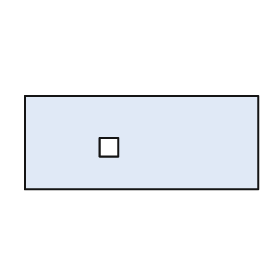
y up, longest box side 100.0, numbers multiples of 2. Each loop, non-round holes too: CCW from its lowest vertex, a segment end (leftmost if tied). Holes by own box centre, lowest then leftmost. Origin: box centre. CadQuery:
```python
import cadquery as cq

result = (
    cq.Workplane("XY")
    .moveTo(-50.0, -20.0)
    .lineTo(50.0, -20.0)
    .lineTo(50.0, 20.0)
    .lineTo(-50.0, 20.0)
    .close()
    .moveTo(-18.0, -6.0)
    .lineTo(-10.0, -6.0)
    .lineTo(-10.0, 2.0)
    .lineTo(-18.0, 2.0)
    .close()
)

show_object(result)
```